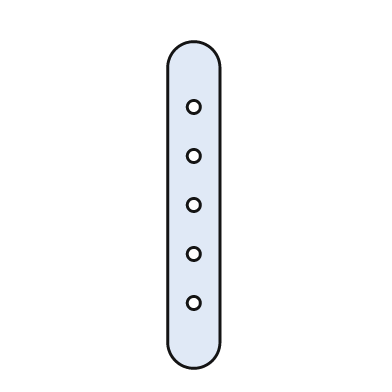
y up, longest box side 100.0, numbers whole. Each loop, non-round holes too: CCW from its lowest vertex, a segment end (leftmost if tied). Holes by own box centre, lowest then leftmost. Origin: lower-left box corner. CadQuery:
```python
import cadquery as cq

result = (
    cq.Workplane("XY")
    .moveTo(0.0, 8.0)
    .threePointArc((8.0, 0.0), (16.0, 8.0))
    .lineTo(16.0, 92.0)
    .threePointArc((8.0, 100.0), (0.0, 92.0))
    .close()
    .moveTo(8.0, 20.0)
    .circle(2.0)
    .moveTo(8.0, 35.0)
    .circle(2.0)
    .moveTo(8.0, 50.0)
    .circle(2.0)
    .moveTo(8.0, 65.0)
    .circle(2.0)
    .moveTo(8.0, 80.0)
    .circle(2.0)
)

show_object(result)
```